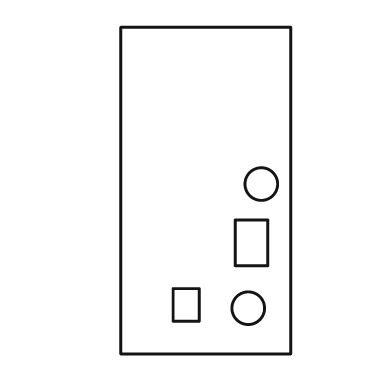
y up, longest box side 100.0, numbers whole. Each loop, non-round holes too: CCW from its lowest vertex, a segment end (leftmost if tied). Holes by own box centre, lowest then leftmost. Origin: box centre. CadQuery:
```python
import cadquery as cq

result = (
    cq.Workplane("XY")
    .moveTo(-26.0, -50.0)
    .lineTo(26.0, -50.0)
    .lineTo(26.0, 50.0)
    .lineTo(-26.0, 50.0)
    .close()
    .moveTo(13.0, -36.0)
    .circle(5.0)
    .moveTo(-10.0, -40.0)
    .lineTo(-2.0, -40.0)
    .lineTo(-2.0, -30.0)
    .lineTo(-10.0, -30.0)
    .close()
    .moveTo(9.0, -23.0)
    .lineTo(19.0, -23.0)
    .lineTo(19.0, -9.0)
    .lineTo(9.0, -9.0)
    .close()
    .moveTo(17.0, 2.0)
    .circle(5.0)
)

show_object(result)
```